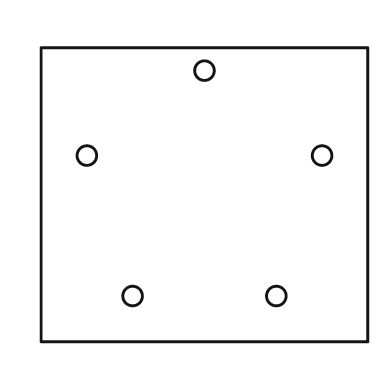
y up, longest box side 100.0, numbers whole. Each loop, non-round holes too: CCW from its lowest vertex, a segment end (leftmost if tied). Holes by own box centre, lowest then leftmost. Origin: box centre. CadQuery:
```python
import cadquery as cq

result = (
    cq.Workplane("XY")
    .moveTo(-50.0, -45.0)
    .lineTo(50.0, -45.0)
    .lineTo(50.0, 45.0)
    .lineTo(-50.0, 45.0)
    .close()
    .moveTo(-22.0, -31.0)
    .circle(3.0)
    .moveTo(22.0, -31.0)
    .circle(3.0)
    .moveTo(-36.0, 12.0)
    .circle(3.0)
    .moveTo(36.0, 12.0)
    .circle(3.0)
    .moveTo(0.0, 38.0)
    .circle(3.0)
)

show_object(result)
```